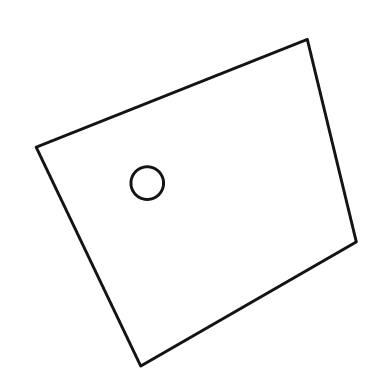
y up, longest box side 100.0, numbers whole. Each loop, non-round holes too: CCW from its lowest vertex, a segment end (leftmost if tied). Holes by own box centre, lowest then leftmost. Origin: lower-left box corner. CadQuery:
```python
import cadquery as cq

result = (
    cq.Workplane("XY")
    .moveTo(32.0, 0.0)
    .lineTo(98.0, 38.0)
    .lineTo(83.0, 100.0)
    .lineTo(0.0, 67.0)
    .close()
    .moveTo(34.0, 56.0)
    .circle(5.0)
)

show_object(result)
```